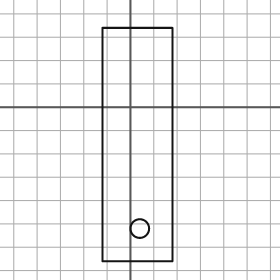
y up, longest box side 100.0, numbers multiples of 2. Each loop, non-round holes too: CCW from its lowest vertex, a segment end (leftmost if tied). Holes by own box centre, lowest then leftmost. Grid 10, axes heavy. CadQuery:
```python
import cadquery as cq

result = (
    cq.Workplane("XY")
    .moveTo(-12.0, -66.0)
    .lineTo(18.0, -66.0)
    .lineTo(18.0, 34.0)
    .lineTo(-12.0, 34.0)
    .close()
    .moveTo(4.0, -52.0)
    .circle(4.0)
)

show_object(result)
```